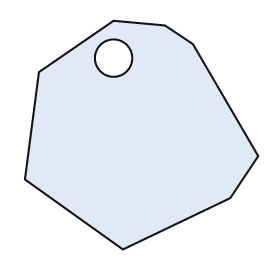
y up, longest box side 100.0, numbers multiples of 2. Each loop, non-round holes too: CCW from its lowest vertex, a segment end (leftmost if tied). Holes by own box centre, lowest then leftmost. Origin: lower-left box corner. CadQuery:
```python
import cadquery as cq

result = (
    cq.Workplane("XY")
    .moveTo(42.0, 0.0)
    .lineTo(88.0, 22.0)
    .lineTo(100.0, 40.0)
    .lineTo(72.0, 88.0)
    .lineTo(60.0, 96.0)
    .lineTo(38.0, 98.0)
    .lineTo(6.0, 76.0)
    .lineTo(0.0, 30.0)
    .close()
    .moveTo(38.0, 82.0)
    .circle(8.0)
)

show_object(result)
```